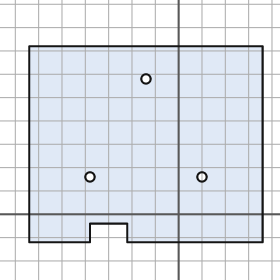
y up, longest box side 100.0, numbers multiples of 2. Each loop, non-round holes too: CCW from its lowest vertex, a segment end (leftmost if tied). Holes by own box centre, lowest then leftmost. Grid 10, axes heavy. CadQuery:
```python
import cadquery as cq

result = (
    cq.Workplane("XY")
    .moveTo(-64.0, -12.0)
    .lineTo(-38.0, -12.0)
    .lineTo(-38.0, -4.0)
    .lineTo(-22.0, -4.0)
    .lineTo(-22.0, -12.0)
    .lineTo(36.0, -12.0)
    .lineTo(36.0, 72.0)
    .lineTo(-64.0, 72.0)
    .close()
    .moveTo(-38.0, 16.0)
    .circle(2.0)
    .moveTo(10.0, 16.0)
    .circle(2.0)
    .moveTo(-14.0, 58.0)
    .circle(2.0)
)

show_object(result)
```